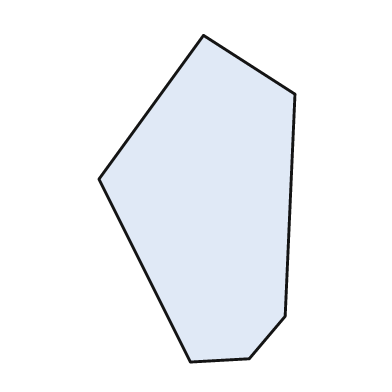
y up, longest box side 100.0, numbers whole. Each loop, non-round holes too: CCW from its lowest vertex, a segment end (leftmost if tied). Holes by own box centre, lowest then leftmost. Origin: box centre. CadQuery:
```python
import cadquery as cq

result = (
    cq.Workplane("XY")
    .moveTo(-2.0, -50.0)
    .lineTo(16.0, -49.0)
    .lineTo(27.0, -36.0)
    .lineTo(30.0, 32.0)
    .lineTo(2.0, 50.0)
    .lineTo(-30.0, 6.0)
    .close()
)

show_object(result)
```